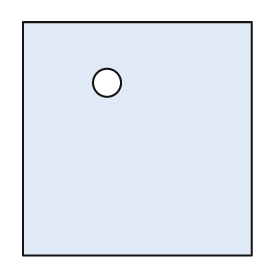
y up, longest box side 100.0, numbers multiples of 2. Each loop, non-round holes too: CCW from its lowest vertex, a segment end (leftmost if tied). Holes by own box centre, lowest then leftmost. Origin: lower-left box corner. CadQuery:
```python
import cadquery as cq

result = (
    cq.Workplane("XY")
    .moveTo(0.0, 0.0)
    .lineTo(98.0, 0.0)
    .lineTo(98.0, 100.0)
    .lineTo(0.0, 100.0)
    .close()
    .moveTo(36.0, 74.0)
    .circle(6.0)
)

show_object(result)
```